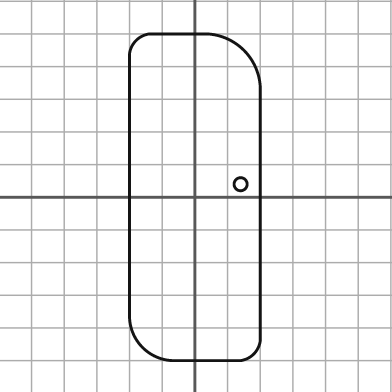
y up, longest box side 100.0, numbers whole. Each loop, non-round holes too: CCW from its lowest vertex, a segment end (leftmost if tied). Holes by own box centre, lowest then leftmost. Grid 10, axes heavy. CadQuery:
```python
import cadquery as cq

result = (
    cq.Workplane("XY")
    .moveTo(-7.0, -50.0)
    .lineTo(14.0, -50.0)
    .threePointArc((18.0, -48.0), (20.0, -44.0))
    .lineTo(20.0, 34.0)
    .threePointArc((15.0, 45.0), (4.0, 50.0))
    .lineTo(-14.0, 50.0)
    .threePointArc((-18.0, 48.0), (-20.0, 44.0))
    .lineTo(-20.0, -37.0)
    .threePointArc((-16.0, -46.0), (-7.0, -50.0))
    .close()
    .moveTo(14.0, 4.0)
    .circle(2.0)
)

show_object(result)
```